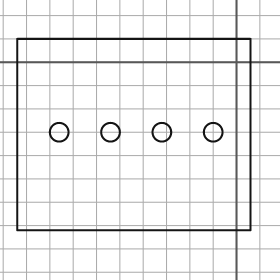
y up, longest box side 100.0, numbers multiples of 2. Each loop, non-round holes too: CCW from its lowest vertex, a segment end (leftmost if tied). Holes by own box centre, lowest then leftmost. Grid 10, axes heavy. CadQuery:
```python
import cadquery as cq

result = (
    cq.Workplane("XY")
    .moveTo(-94.0, -72.0)
    .lineTo(6.0, -72.0)
    .lineTo(6.0, 10.0)
    .lineTo(-94.0, 10.0)
    .close()
    .moveTo(-76.0, -30.0)
    .circle(4.0)
    .moveTo(-54.0, -30.0)
    .circle(4.0)
    .moveTo(-32.0, -30.0)
    .circle(4.0)
    .moveTo(-10.0, -30.0)
    .circle(4.0)
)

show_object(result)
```